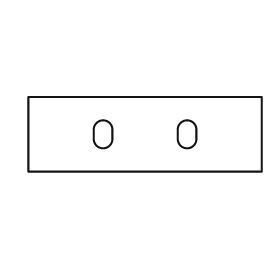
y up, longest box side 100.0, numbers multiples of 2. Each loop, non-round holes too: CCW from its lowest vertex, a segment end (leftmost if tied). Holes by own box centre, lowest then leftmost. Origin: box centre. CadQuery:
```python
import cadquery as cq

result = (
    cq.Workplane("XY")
    .moveTo(-50.0, -16.0)
    .lineTo(50.0, -16.0)
    .lineTo(50.0, 16.0)
    .lineTo(-50.0, 16.0)
    .close()
    .moveTo(-22.0, -2.0)
    .threePointArc((-18.0, -6.0), (-14.0, -2.0))
    .lineTo(-14.0, 2.0)
    .threePointArc((-18.0, 6.0), (-22.0, 2.0))
    .close()
    .moveTo(14.0, -2.0)
    .threePointArc((18.0, -6.0), (22.0, -2.0))
    .lineTo(22.0, 2.0)
    .threePointArc((18.0, 6.0), (14.0, 2.0))
    .close()
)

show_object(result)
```